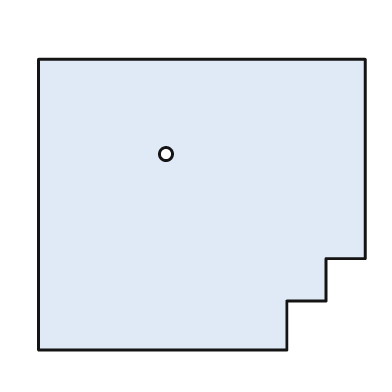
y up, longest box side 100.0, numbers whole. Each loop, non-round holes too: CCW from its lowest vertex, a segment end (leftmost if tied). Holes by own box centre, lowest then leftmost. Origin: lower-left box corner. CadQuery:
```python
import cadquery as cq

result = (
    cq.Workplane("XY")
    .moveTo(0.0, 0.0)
    .lineTo(76.0, 0.0)
    .lineTo(76.0, 15.0)
    .lineTo(88.0, 15.0)
    .lineTo(88.0, 28.0)
    .lineTo(100.0, 28.0)
    .lineTo(100.0, 89.0)
    .lineTo(0.0, 89.0)
    .close()
    .moveTo(39.0, 60.0)
    .circle(2.0)
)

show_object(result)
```